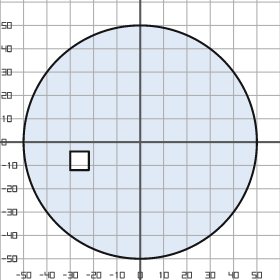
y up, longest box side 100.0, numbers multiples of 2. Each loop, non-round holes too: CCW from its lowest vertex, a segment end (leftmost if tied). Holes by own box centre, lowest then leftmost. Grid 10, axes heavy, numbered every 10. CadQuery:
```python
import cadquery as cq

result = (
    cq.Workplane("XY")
    .moveTo(0.0, 0.0)
    .circle(50.0)
    .moveTo(-30.0, -12.0)
    .lineTo(-22.0, -12.0)
    .lineTo(-22.0, -4.0)
    .lineTo(-30.0, -4.0)
    .close()
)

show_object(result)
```